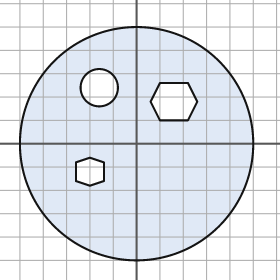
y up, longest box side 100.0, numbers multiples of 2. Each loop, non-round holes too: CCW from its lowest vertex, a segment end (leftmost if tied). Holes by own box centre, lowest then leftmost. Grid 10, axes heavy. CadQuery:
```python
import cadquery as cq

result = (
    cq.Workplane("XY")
    .moveTo(0.0, 0.0)
    .circle(50.0)
    .moveTo(-20.0, -18.0)
    .lineTo(-14.0, -16.0)
    .lineTo(-14.0, -8.0)
    .lineTo(-20.0, -6.0)
    .lineTo(-26.0, -8.0)
    .lineTo(-26.0, -16.0)
    .close()
    .moveTo(10.0, 10.0)
    .lineTo(22.0, 10.0)
    .lineTo(26.0, 18.0)
    .lineTo(22.0, 26.0)
    .lineTo(10.0, 26.0)
    .lineTo(6.0, 18.0)
    .close()
    .moveTo(-16.0, 24.0)
    .circle(8.0)
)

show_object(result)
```